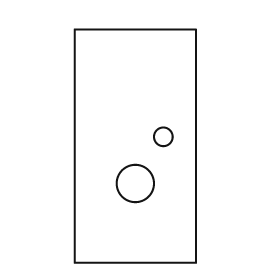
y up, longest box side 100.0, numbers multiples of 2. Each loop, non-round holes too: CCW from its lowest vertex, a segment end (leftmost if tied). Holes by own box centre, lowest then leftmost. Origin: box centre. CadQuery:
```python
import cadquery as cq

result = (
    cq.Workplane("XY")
    .moveTo(-26.0, -50.0)
    .lineTo(26.0, -50.0)
    .lineTo(26.0, 50.0)
    .lineTo(-26.0, 50.0)
    .close()
    .moveTo(0.0, -16.0)
    .circle(8.0)
    .moveTo(12.0, 4.0)
    .circle(4.0)
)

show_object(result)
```